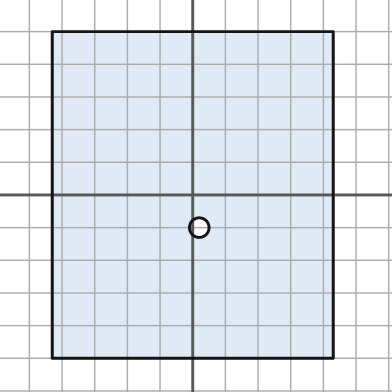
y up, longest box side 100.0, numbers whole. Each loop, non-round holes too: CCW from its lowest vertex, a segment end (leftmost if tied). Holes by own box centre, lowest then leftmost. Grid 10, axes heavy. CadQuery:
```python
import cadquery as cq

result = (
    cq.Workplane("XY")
    .moveTo(-43.0, -50.0)
    .lineTo(43.0, -50.0)
    .lineTo(43.0, 50.0)
    .lineTo(-43.0, 50.0)
    .close()
    .moveTo(2.0, -10.0)
    .circle(3.0)
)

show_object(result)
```